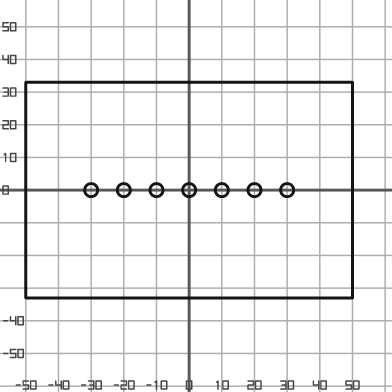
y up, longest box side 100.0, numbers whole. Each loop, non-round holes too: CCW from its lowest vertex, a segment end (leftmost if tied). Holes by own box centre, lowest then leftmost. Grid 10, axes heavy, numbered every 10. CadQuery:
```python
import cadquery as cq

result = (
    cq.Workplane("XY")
    .moveTo(-50.0, -33.0)
    .lineTo(50.0, -33.0)
    .lineTo(50.0, 33.0)
    .lineTo(-50.0, 33.0)
    .close()
    .moveTo(-30.0, 0.0)
    .circle(2.0)
    .moveTo(-20.0, 0.0)
    .circle(2.0)
    .moveTo(-10.0, 0.0)
    .circle(2.0)
    .moveTo(0.0, 0.0)
    .circle(2.0)
    .moveTo(10.0, 0.0)
    .circle(2.0)
    .moveTo(20.0, 0.0)
    .circle(2.0)
    .moveTo(30.0, 0.0)
    .circle(2.0)
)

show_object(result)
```